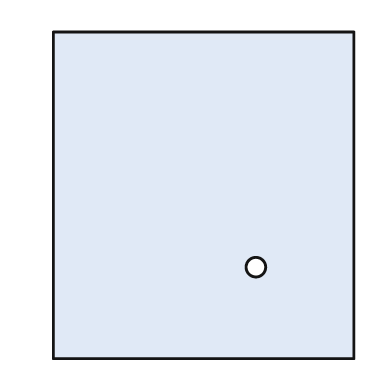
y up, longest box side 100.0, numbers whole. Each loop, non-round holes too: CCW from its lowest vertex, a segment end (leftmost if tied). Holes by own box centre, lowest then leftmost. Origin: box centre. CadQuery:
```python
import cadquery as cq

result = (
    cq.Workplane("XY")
    .moveTo(-46.0, -50.0)
    .lineTo(46.0, -50.0)
    .lineTo(46.0, 50.0)
    .lineTo(-46.0, 50.0)
    .close()
    .moveTo(16.0, -22.0)
    .circle(3.0)
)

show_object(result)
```